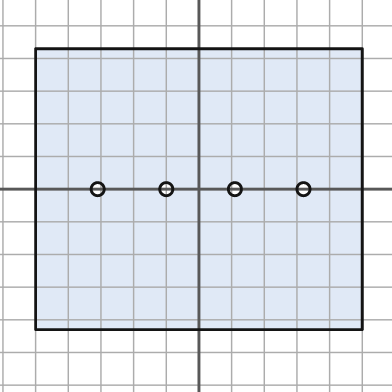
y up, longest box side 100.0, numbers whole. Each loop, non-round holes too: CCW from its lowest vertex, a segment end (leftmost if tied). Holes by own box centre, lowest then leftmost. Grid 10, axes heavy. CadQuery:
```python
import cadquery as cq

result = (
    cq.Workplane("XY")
    .moveTo(-50.0, -43.0)
    .lineTo(50.0, -43.0)
    .lineTo(50.0, 43.0)
    .lineTo(-50.0, 43.0)
    .close()
    .moveTo(-31.0, 0.0)
    .circle(2.0)
    .moveTo(-10.0, 0.0)
    .circle(2.0)
    .moveTo(11.0, 0.0)
    .circle(2.0)
    .moveTo(32.0, 0.0)
    .circle(2.0)
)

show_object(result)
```